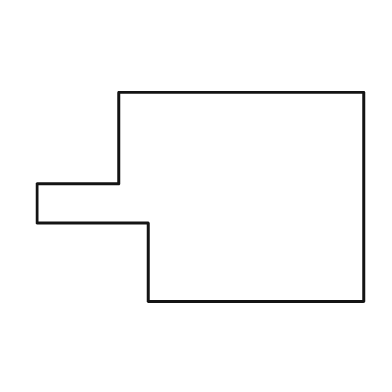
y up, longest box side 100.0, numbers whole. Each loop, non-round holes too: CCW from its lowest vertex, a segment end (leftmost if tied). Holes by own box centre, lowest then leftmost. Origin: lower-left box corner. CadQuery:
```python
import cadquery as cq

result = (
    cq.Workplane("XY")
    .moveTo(34.0, 0.0)
    .lineTo(100.0, 0.0)
    .lineTo(100.0, 64.0)
    .lineTo(25.0, 64.0)
    .lineTo(25.0, 36.0)
    .lineTo(0.0, 36.0)
    .lineTo(0.0, 24.0)
    .lineTo(34.0, 24.0)
    .close()
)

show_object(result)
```